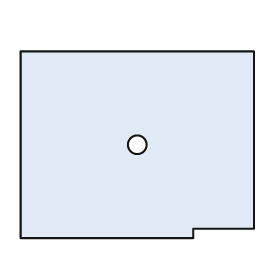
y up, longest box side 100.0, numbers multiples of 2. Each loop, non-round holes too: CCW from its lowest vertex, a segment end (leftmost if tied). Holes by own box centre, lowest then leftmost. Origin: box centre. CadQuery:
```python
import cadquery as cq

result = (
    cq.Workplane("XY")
    .moveTo(-50.0, -40.0)
    .lineTo(24.0, -40.0)
    .lineTo(24.0, -36.0)
    .lineTo(50.0, -36.0)
    .lineTo(50.0, 40.0)
    .lineTo(-50.0, 40.0)
    .close()
    .moveTo(0.0, 0.0)
    .circle(4.0)
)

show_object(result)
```